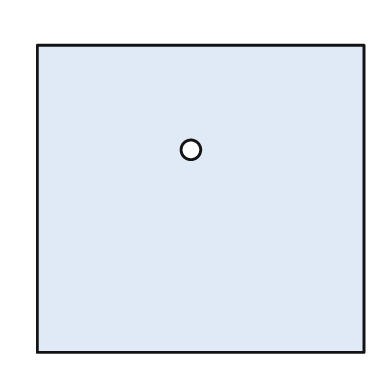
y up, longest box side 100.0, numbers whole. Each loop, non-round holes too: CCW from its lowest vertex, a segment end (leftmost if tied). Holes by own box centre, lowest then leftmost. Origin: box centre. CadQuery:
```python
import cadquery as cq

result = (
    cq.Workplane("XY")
    .moveTo(-50.0, -47.0)
    .lineTo(50.0, -47.0)
    .lineTo(50.0, 47.0)
    .lineTo(-50.0, 47.0)
    .close()
    .moveTo(-3.0, 15.0)
    .circle(3.0)
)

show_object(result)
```